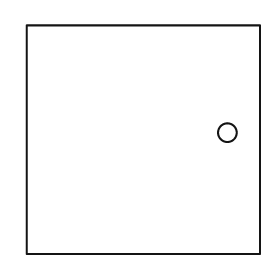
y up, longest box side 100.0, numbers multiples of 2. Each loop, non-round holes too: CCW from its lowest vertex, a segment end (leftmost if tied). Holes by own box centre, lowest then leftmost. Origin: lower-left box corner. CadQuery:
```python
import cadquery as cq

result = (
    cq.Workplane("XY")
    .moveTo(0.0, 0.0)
    .lineTo(100.0, 0.0)
    .lineTo(100.0, 98.0)
    .lineTo(0.0, 98.0)
    .close()
    .moveTo(86.0, 52.0)
    .circle(4.0)
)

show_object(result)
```